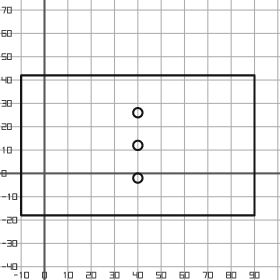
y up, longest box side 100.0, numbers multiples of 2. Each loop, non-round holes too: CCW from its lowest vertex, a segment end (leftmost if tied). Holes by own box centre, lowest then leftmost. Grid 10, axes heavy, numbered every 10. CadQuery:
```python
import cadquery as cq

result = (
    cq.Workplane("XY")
    .moveTo(-10.0, -18.0)
    .lineTo(90.0, -18.0)
    .lineTo(90.0, 42.0)
    .lineTo(-10.0, 42.0)
    .close()
    .moveTo(40.0, -2.0)
    .circle(2.0)
    .moveTo(40.0, 12.0)
    .circle(2.0)
    .moveTo(40.0, 26.0)
    .circle(2.0)
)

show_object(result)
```